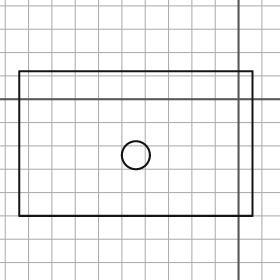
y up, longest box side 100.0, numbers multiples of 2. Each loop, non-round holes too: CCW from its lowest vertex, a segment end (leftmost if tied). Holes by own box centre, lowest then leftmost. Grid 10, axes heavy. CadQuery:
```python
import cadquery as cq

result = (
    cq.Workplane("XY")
    .moveTo(-94.0, -50.0)
    .lineTo(6.0, -50.0)
    .lineTo(6.0, 12.0)
    .lineTo(-94.0, 12.0)
    .close()
    .moveTo(-44.0, -24.0)
    .circle(6.0)
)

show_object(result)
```